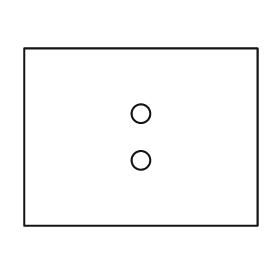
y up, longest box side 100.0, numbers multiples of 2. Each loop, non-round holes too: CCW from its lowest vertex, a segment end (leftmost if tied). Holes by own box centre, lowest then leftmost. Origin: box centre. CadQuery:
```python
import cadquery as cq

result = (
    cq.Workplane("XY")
    .moveTo(-50.0, -38.0)
    .lineTo(50.0, -38.0)
    .lineTo(50.0, 38.0)
    .lineTo(-50.0, 38.0)
    .close()
    .moveTo(0.0, -10.0)
    .circle(4.0)
    .moveTo(0.0, 10.0)
    .circle(4.0)
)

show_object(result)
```